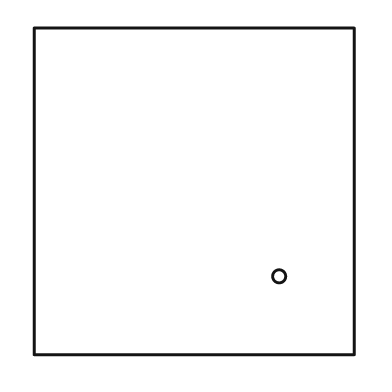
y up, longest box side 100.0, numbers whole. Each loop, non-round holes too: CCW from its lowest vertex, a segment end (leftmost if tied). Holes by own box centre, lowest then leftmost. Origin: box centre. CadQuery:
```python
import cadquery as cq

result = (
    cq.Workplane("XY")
    .moveTo(-49.0, -50.0)
    .lineTo(49.0, -50.0)
    .lineTo(49.0, 50.0)
    .lineTo(-49.0, 50.0)
    .close()
    .moveTo(26.0, -26.0)
    .circle(2.0)
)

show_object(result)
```